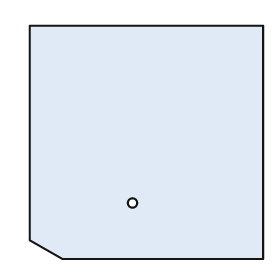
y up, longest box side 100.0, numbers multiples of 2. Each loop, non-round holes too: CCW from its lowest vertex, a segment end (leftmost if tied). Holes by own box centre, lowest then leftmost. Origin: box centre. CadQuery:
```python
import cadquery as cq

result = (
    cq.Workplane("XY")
    .moveTo(-36.0, -50.0)
    .lineTo(50.0, -50.0)
    .lineTo(50.0, 50.0)
    .lineTo(-50.0, 50.0)
    .lineTo(-50.0, -42.0)
    .close()
    .moveTo(-6.0, -26.0)
    .circle(2.0)
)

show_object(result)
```